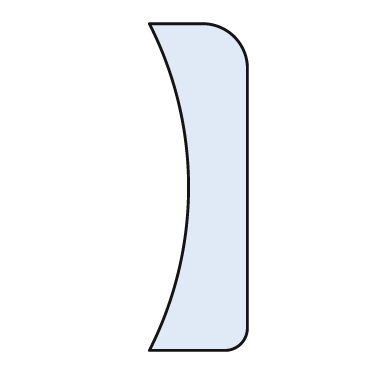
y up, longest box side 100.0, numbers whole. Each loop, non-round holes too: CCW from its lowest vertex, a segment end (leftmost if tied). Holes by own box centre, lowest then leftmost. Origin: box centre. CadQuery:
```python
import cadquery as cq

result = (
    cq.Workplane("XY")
    .moveTo(-15.0, -50.0)
    .lineTo(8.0, -50.0)
    .threePointArc((13.0, -48.0), (15.0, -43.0))
    .lineTo(15.0, 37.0)
    .threePointArc((11.0, 46.0), (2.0, 50.0))
    .lineTo(-15.0, 50.0)
    .threePointArc((-3.0, 0.0), (-15.0, -50.0))
    .close()
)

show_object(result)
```